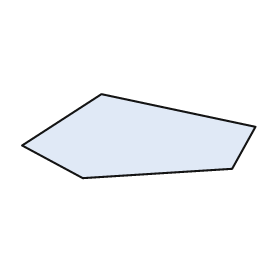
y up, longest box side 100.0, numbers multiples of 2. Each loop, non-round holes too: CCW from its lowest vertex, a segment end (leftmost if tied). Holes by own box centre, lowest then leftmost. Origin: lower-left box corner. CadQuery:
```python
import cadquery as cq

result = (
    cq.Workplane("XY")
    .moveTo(26.0, 0.0)
    .lineTo(90.0, 4.0)
    .lineTo(100.0, 22.0)
    .lineTo(34.0, 36.0)
    .lineTo(0.0, 14.0)
    .close()
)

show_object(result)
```